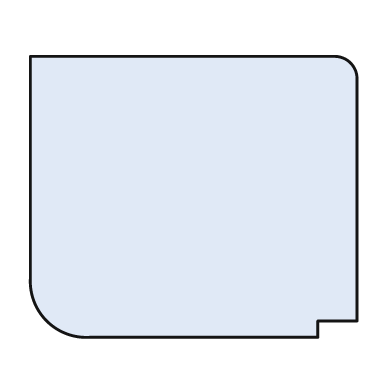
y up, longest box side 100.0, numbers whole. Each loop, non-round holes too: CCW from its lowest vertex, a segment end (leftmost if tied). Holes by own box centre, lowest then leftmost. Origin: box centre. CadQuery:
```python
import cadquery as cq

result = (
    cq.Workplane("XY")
    .moveTo(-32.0, -43.0)
    .lineTo(38.0, -43.0)
    .lineTo(38.0, -38.0)
    .lineTo(50.0, -38.0)
    .lineTo(50.0, 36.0)
    .threePointArc((48.0, 41.0), (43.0, 43.0))
    .lineTo(-50.0, 43.0)
    .lineTo(-50.0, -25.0)
    .threePointArc((-45.0, -38.0), (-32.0, -43.0))
    .close()
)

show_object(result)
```